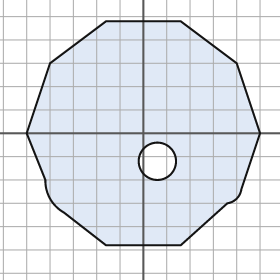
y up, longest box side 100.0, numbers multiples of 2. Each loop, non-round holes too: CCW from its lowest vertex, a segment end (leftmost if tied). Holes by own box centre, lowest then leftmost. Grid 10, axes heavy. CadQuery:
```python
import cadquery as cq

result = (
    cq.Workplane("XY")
    .moveTo(-16.0, -48.0)
    .lineTo(16.0, -48.0)
    .lineTo(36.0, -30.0)
    .threePointArc((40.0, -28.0), (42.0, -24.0))
    .lineTo(50.0, 0.0)
    .lineTo(40.0, 30.0)
    .lineTo(16.0, 48.0)
    .lineTo(-16.0, 48.0)
    .lineTo(-40.0, 30.0)
    .lineTo(-50.0, 0.0)
    .lineTo(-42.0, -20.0)
    .threePointArc((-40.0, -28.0), (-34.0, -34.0))
    .close()
    .moveTo(6.0, -12.0)
    .circle(8.0)
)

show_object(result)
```